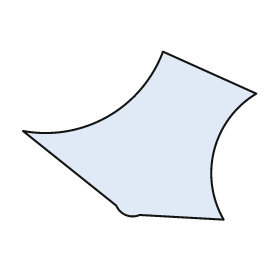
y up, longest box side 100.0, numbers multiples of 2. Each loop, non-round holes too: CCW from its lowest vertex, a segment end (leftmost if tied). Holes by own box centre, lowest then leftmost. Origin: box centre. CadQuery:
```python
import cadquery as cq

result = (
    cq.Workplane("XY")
    .moveTo(36.0, -36.0)
    .threePointArc((32.0, -6.0), (50.0, 18.0))
    .lineTo(10.0, 36.0)
    .threePointArc((-14.0, 8.0), (-50.0, 2.0))
    .lineTo(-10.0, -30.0)
    .threePointArc((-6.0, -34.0), (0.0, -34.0))
    .close()
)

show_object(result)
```